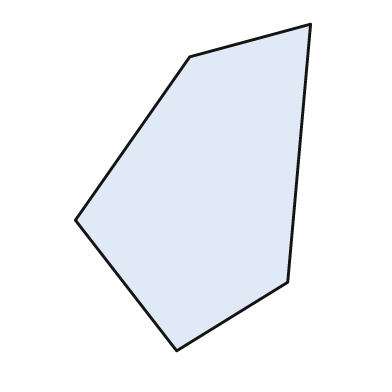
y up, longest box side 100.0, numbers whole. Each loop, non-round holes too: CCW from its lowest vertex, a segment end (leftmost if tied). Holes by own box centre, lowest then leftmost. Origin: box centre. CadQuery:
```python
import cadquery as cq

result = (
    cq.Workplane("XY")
    .moveTo(-5.0, -50.0)
    .lineTo(29.0, -29.0)
    .lineTo(36.0, 50.0)
    .lineTo(-1.0, 40.0)
    .lineTo(-36.0, -10.0)
    .close()
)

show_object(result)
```